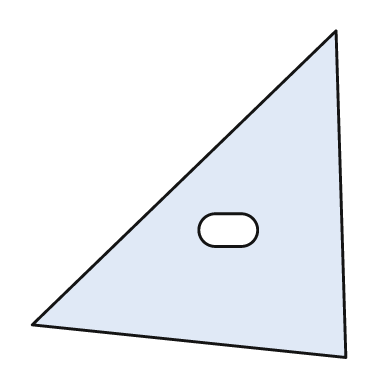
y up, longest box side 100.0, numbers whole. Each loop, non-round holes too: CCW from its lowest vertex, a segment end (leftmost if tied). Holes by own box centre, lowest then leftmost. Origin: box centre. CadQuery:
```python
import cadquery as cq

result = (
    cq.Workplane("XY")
    .moveTo(48.0, -50.0)
    .lineTo(45.0, 50.0)
    .lineTo(-48.0, -40.0)
    .close()
    .moveTo(8.0, -16.0)
    .lineTo(16.0, -16.0)
    .threePointArc((21.0, -11.0), (16.0, -6.0))
    .lineTo(8.0, -6.0)
    .threePointArc((3.0, -11.0), (8.0, -16.0))
    .close()
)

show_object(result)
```